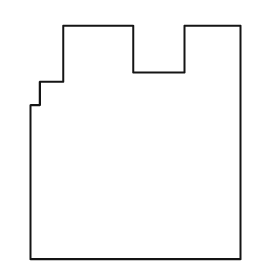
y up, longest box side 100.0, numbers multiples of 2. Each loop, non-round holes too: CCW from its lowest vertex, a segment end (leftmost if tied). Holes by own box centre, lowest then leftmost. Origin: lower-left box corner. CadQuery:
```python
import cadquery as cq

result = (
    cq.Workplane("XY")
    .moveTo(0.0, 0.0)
    .lineTo(90.0, 0.0)
    .lineTo(90.0, 100.0)
    .lineTo(66.0, 100.0)
    .lineTo(66.0, 80.0)
    .lineTo(44.0, 80.0)
    .lineTo(44.0, 100.0)
    .lineTo(14.0, 100.0)
    .lineTo(14.0, 76.0)
    .lineTo(4.0, 76.0)
    .lineTo(4.0, 66.0)
    .lineTo(0.0, 66.0)
    .close()
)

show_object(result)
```